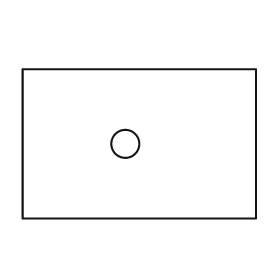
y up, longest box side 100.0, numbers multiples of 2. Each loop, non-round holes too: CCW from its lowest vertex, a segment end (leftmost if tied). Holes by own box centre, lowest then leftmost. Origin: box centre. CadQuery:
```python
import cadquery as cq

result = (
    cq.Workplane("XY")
    .moveTo(-50.0, -32.0)
    .lineTo(50.0, -32.0)
    .lineTo(50.0, 32.0)
    .lineTo(-50.0, 32.0)
    .close()
    .moveTo(-6.0, 0.0)
    .circle(6.0)
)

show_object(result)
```